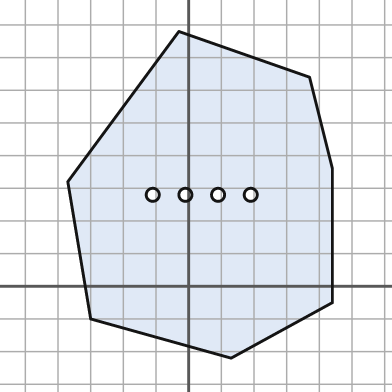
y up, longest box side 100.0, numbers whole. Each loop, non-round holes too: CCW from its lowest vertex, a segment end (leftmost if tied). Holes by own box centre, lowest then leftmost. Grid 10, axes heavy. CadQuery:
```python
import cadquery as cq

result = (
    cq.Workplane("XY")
    .moveTo(13.0, -22.0)
    .lineTo(44.0, -5.0)
    .lineTo(44.0, 36.0)
    .lineTo(37.0, 64.0)
    .lineTo(-3.0, 78.0)
    .lineTo(-37.0, 32.0)
    .lineTo(-30.0, -10.0)
    .close()
    .moveTo(-11.0, 28.0)
    .circle(2.0)
    .moveTo(-1.0, 28.0)
    .circle(2.0)
    .moveTo(9.0, 28.0)
    .circle(2.0)
    .moveTo(19.0, 28.0)
    .circle(2.0)
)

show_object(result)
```